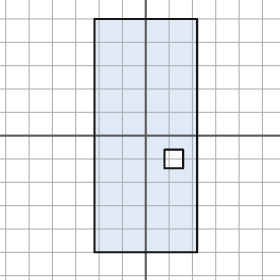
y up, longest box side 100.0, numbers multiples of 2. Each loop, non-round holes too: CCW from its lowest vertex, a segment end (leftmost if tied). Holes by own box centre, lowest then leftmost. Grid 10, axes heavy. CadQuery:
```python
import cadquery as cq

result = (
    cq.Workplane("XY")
    .moveTo(-22.0, -50.0)
    .lineTo(22.0, -50.0)
    .lineTo(22.0, 50.0)
    .lineTo(-22.0, 50.0)
    .close()
    .moveTo(8.0, -14.0)
    .lineTo(16.0, -14.0)
    .lineTo(16.0, -6.0)
    .lineTo(8.0, -6.0)
    .close()
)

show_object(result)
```